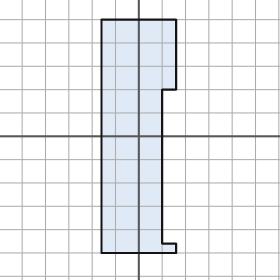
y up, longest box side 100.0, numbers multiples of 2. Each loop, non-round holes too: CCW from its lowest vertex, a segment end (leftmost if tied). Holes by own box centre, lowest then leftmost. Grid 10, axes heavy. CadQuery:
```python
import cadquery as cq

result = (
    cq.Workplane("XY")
    .moveTo(-16.0, -50.0)
    .lineTo(16.0, -50.0)
    .lineTo(16.0, -46.0)
    .lineTo(10.0, -46.0)
    .lineTo(10.0, 20.0)
    .lineTo(16.0, 20.0)
    .lineTo(16.0, 50.0)
    .lineTo(-16.0, 50.0)
    .close()
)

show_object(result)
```